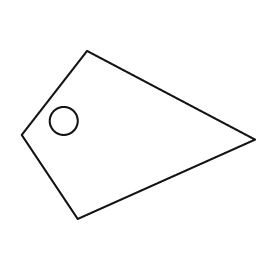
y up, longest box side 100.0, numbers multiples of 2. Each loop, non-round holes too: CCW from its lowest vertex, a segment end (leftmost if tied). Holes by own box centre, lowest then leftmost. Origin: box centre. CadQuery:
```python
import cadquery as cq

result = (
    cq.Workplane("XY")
    .moveTo(-26.0, -36.0)
    .lineTo(50.0, -2.0)
    .lineTo(-22.0, 36.0)
    .lineTo(-50.0, 0.0)
    .close()
    .moveTo(-32.0, 6.0)
    .circle(6.0)
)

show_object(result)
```